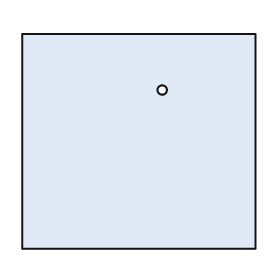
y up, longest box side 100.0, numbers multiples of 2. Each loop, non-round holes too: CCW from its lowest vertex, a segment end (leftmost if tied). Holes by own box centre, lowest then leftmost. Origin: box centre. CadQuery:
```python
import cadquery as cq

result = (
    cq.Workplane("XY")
    .moveTo(-50.0, -46.0)
    .lineTo(50.0, -46.0)
    .lineTo(50.0, 46.0)
    .lineTo(-50.0, 46.0)
    .close()
    .moveTo(10.0, 22.0)
    .circle(2.0)
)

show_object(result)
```